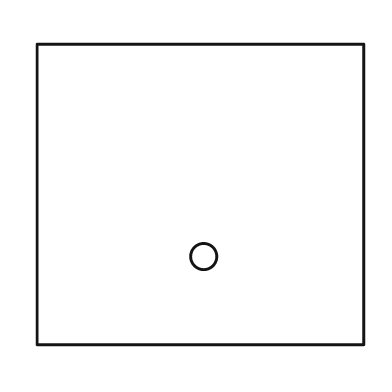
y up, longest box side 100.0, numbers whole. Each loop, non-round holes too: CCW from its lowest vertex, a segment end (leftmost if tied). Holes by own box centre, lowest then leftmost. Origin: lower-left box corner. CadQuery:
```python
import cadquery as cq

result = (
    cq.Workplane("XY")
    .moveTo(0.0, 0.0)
    .lineTo(100.0, 0.0)
    .lineTo(100.0, 92.0)
    .lineTo(0.0, 92.0)
    .close()
    .moveTo(51.0, 27.0)
    .circle(4.0)
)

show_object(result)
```